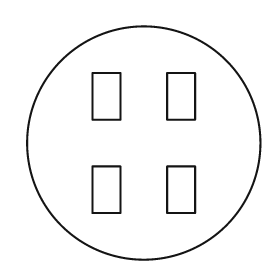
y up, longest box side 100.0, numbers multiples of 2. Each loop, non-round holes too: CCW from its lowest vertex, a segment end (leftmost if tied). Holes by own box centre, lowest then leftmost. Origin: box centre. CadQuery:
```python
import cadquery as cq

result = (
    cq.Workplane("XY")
    .moveTo(0.0, 0.0)
    .circle(50.0)
    .moveTo(-22.0, -30.0)
    .lineTo(-10.0, -30.0)
    .lineTo(-10.0, -10.0)
    .lineTo(-22.0, -10.0)
    .close()
    .moveTo(10.0, -30.0)
    .lineTo(22.0, -30.0)
    .lineTo(22.0, -10.0)
    .lineTo(10.0, -10.0)
    .close()
    .moveTo(-22.0, 10.0)
    .lineTo(-10.0, 10.0)
    .lineTo(-10.0, 30.0)
    .lineTo(-22.0, 30.0)
    .close()
    .moveTo(10.0, 10.0)
    .lineTo(22.0, 10.0)
    .lineTo(22.0, 30.0)
    .lineTo(10.0, 30.0)
    .close()
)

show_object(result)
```